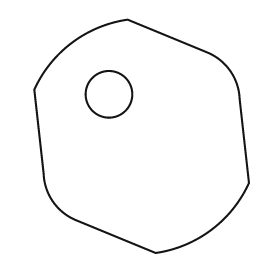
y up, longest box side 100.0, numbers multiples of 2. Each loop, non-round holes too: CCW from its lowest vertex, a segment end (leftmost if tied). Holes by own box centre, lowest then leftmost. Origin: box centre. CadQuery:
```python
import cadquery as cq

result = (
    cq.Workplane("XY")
    .moveTo(6.0, -50.0)
    .threePointArc((30.0, -40.0), (46.0, -20.0))
    .lineTo(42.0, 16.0)
    .threePointArc((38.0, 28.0), (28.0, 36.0))
    .lineTo(-6.0, 50.0)
    .threePointArc((-30.0, 40.0), (-46.0, 20.0))
    .lineTo(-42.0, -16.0)
    .threePointArc((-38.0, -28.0), (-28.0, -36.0))
    .close()
    .moveTo(-14.0, 18.0)
    .circle(10.0)
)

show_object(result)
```